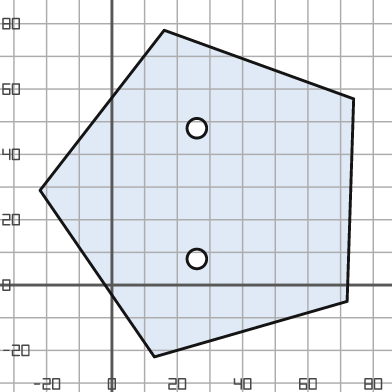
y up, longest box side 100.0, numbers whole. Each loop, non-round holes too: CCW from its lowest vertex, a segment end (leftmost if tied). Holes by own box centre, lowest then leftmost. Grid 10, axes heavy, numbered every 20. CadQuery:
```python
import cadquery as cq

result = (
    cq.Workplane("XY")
    .moveTo(13.0, -22.0)
    .lineTo(72.0, -5.0)
    .lineTo(74.0, 57.0)
    .lineTo(16.0, 78.0)
    .lineTo(-22.0, 29.0)
    .close()
    .moveTo(26.0, 8.0)
    .circle(3.0)
    .moveTo(26.0, 48.0)
    .circle(3.0)
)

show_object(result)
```